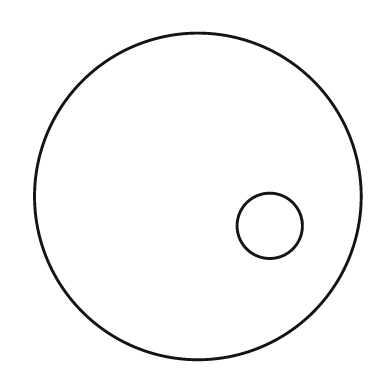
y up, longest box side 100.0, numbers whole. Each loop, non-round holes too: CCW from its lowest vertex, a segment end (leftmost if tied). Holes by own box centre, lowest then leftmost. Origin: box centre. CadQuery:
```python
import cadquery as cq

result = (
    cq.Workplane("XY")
    .moveTo(0.0, 0.0)
    .circle(50.0)
    .moveTo(22.0, -9.0)
    .circle(10.0)
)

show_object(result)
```